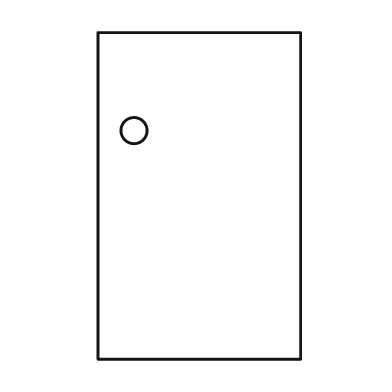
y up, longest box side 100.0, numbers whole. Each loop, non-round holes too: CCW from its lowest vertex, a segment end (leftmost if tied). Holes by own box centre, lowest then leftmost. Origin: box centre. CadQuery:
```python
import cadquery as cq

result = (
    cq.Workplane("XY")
    .moveTo(-31.0, -50.0)
    .lineTo(31.0, -50.0)
    .lineTo(31.0, 50.0)
    .lineTo(-31.0, 50.0)
    .close()
    .moveTo(-20.0, 20.0)
    .circle(4.0)
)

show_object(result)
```